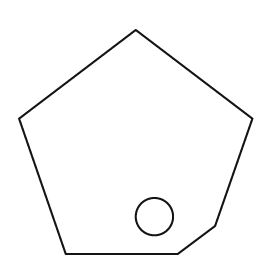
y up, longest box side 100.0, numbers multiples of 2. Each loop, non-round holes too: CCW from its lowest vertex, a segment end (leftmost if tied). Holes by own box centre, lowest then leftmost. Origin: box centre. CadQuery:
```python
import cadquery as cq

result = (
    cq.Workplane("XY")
    .moveTo(-30.0, -48.0)
    .lineTo(18.0, -48.0)
    .lineTo(34.0, -36.0)
    .lineTo(50.0, 10.0)
    .lineTo(0.0, 48.0)
    .lineTo(-50.0, 10.0)
    .close()
    .moveTo(8.0, -32.0)
    .circle(8.0)
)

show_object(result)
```